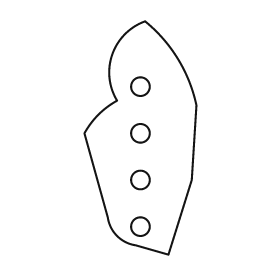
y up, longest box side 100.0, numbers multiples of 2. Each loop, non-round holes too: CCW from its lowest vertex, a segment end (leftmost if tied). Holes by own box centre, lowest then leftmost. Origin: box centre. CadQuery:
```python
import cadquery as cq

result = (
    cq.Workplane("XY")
    .moveTo(12.0, -50.0)
    .lineTo(22.0, -18.0)
    .lineTo(24.0, 14.0)
    .threePointArc((16.0, 34.0), (2.0, 50.0))
    .threePointArc((-12.0, 36.0), (-10.0, 16.0))
    .threePointArc((-18.0, 10.0), (-24.0, 2.0))
    .lineTo(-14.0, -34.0)
    .threePointArc((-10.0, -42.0), (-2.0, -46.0))
    .close()
    .moveTo(0.0, -38.0)
    .circle(4.0)
    .moveTo(0.0, -18.0)
    .circle(4.0)
    .moveTo(0.0, 2.0)
    .circle(4.0)
    .moveTo(0.0, 22.0)
    .circle(4.0)
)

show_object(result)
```